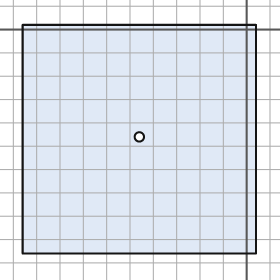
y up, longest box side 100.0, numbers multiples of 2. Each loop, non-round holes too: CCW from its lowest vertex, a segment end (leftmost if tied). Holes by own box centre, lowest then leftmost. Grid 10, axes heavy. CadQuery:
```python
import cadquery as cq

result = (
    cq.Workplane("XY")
    .moveTo(-96.0, -96.0)
    .lineTo(4.0, -96.0)
    .lineTo(4.0, 2.0)
    .lineTo(-96.0, 2.0)
    .close()
    .moveTo(-46.0, -46.0)
    .circle(2.0)
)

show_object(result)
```